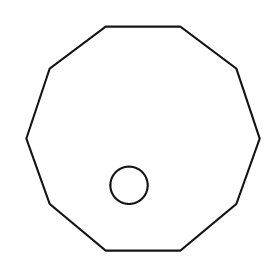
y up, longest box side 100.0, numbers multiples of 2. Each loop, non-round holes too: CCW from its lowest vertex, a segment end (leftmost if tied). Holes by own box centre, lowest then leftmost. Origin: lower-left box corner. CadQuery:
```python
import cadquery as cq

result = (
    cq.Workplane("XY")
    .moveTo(34.0, 0.0)
    .lineTo(66.0, 0.0)
    .lineTo(90.0, 20.0)
    .lineTo(100.0, 48.0)
    .lineTo(90.0, 78.0)
    .lineTo(66.0, 96.0)
    .lineTo(34.0, 96.0)
    .lineTo(10.0, 78.0)
    .lineTo(0.0, 48.0)
    .lineTo(10.0, 20.0)
    .close()
    .moveTo(44.0, 28.0)
    .circle(8.0)
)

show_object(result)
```